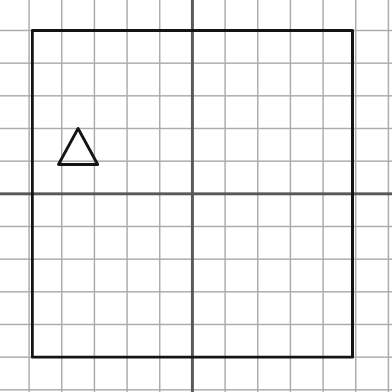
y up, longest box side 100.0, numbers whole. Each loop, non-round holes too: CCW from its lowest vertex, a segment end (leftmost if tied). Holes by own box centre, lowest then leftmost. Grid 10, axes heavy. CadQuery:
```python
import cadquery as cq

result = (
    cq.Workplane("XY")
    .moveTo(-49.0, -50.0)
    .lineTo(49.0, -50.0)
    .lineTo(49.0, 50.0)
    .lineTo(-49.0, 50.0)
    .close()
    .moveTo(-41.0, 9.0)
    .lineTo(-29.0, 9.0)
    .lineTo(-35.0, 20.0)
    .close()
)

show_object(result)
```